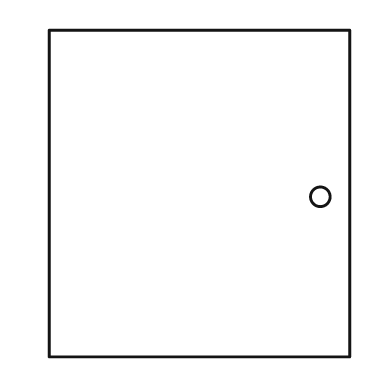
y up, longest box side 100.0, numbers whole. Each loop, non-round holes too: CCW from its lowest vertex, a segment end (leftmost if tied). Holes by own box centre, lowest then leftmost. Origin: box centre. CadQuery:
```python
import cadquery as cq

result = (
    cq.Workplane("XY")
    .moveTo(-46.0, -50.0)
    .lineTo(46.0, -50.0)
    .lineTo(46.0, 50.0)
    .lineTo(-46.0, 50.0)
    .close()
    .moveTo(37.0, -1.0)
    .circle(3.0)
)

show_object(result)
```